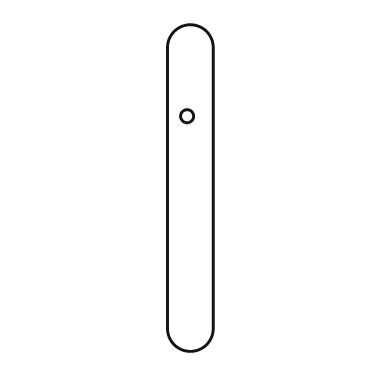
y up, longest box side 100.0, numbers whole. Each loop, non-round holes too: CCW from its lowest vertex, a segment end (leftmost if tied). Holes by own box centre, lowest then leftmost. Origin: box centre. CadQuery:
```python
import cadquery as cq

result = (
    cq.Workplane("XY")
    .moveTo(-7.0, -43.0)
    .threePointArc((0.0, -50.0), (7.0, -43.0))
    .lineTo(7.0, 43.0)
    .threePointArc((0.0, 50.0), (-7.0, 43.0))
    .close()
    .moveTo(-1.0, 22.0)
    .circle(2.0)
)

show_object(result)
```